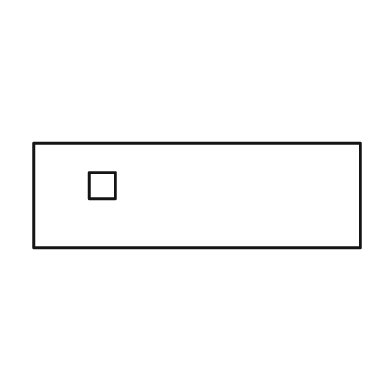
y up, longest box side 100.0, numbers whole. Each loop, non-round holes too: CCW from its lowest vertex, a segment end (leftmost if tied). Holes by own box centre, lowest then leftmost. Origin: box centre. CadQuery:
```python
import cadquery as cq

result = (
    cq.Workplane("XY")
    .moveTo(-50.0, -16.0)
    .lineTo(50.0, -16.0)
    .lineTo(50.0, 16.0)
    .lineTo(-50.0, 16.0)
    .close()
    .moveTo(-33.0, -1.0)
    .lineTo(-25.0, -1.0)
    .lineTo(-25.0, 7.0)
    .lineTo(-33.0, 7.0)
    .close()
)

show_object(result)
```